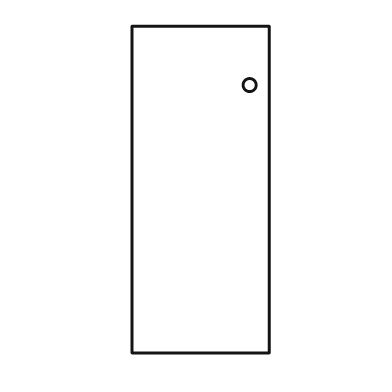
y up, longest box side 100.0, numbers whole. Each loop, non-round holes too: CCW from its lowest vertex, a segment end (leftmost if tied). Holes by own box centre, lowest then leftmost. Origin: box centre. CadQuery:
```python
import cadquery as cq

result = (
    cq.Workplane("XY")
    .moveTo(-21.0, -50.0)
    .lineTo(21.0, -50.0)
    .lineTo(21.0, 50.0)
    .lineTo(-21.0, 50.0)
    .close()
    .moveTo(15.0, 32.0)
    .circle(2.0)
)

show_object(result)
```